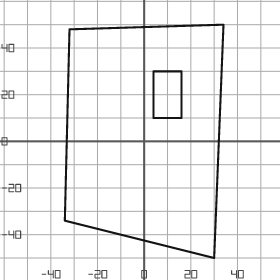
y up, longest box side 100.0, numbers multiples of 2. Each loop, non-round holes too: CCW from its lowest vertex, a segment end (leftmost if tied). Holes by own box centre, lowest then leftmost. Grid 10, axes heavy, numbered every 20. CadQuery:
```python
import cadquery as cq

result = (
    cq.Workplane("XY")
    .moveTo(30.0, -50.0)
    .lineTo(34.0, 50.0)
    .lineTo(-32.0, 48.0)
    .lineTo(-34.0, -34.0)
    .close()
    .moveTo(4.0, 10.0)
    .lineTo(16.0, 10.0)
    .lineTo(16.0, 30.0)
    .lineTo(4.0, 30.0)
    .close()
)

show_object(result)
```